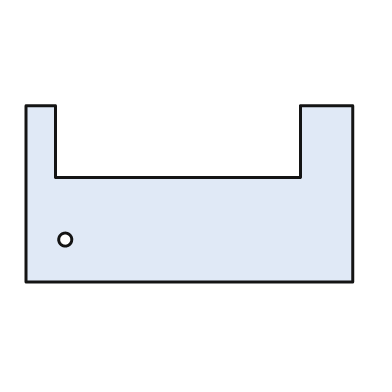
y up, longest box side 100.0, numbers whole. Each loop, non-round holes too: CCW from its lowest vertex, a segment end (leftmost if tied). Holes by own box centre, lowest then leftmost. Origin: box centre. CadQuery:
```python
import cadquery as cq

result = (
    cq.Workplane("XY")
    .moveTo(-50.0, -27.0)
    .lineTo(50.0, -27.0)
    .lineTo(50.0, 27.0)
    .lineTo(34.0, 27.0)
    .lineTo(34.0, 5.0)
    .lineTo(-41.0, 5.0)
    .lineTo(-41.0, 27.0)
    .lineTo(-50.0, 27.0)
    .close()
    .moveTo(-38.0, -14.0)
    .circle(2.0)
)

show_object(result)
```